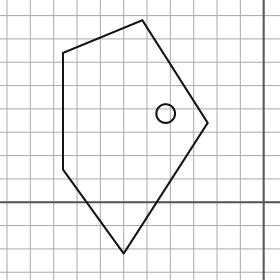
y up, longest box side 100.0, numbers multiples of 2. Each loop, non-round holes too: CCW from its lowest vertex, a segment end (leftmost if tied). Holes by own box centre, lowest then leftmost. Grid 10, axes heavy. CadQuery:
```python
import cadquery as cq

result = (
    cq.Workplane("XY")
    .moveTo(-60.0, -22.0)
    .lineTo(-24.0, 34.0)
    .lineTo(-52.0, 78.0)
    .lineTo(-86.0, 64.0)
    .lineTo(-86.0, 14.0)
    .close()
    .moveTo(-42.0, 38.0)
    .circle(4.0)
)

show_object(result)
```